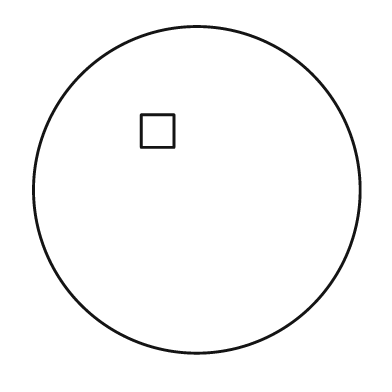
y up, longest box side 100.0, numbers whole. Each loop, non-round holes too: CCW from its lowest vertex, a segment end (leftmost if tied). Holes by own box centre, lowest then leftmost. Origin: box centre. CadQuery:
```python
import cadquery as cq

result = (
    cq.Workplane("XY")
    .moveTo(0.0, 0.0)
    .circle(50.0)
    .moveTo(-17.0, 13.0)
    .lineTo(-7.0, 13.0)
    .lineTo(-7.0, 23.0)
    .lineTo(-17.0, 23.0)
    .close()
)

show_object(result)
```